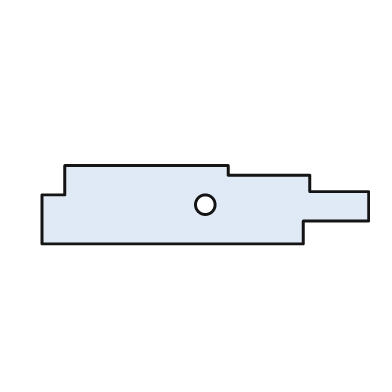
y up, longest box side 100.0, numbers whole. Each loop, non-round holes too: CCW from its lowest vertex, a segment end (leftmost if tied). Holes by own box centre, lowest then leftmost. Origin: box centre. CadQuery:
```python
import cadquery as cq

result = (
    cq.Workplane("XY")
    .moveTo(-50.0, -12.0)
    .lineTo(30.0, -12.0)
    .lineTo(30.0, -5.0)
    .lineTo(50.0, -5.0)
    .lineTo(50.0, 4.0)
    .lineTo(32.0, 4.0)
    .lineTo(32.0, 9.0)
    .lineTo(7.0, 9.0)
    .lineTo(7.0, 12.0)
    .lineTo(-43.0, 12.0)
    .lineTo(-43.0, 3.0)
    .lineTo(-50.0, 3.0)
    .close()
    .moveTo(0.0, 0.0)
    .circle(3.0)
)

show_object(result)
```